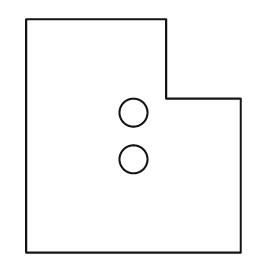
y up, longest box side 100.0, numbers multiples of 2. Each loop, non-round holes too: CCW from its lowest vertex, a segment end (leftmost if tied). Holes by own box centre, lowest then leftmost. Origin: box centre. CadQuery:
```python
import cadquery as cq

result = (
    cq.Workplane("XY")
    .moveTo(-46.0, -50.0)
    .lineTo(46.0, -50.0)
    .lineTo(46.0, 16.0)
    .lineTo(14.0, 16.0)
    .lineTo(14.0, 50.0)
    .lineTo(-46.0, 50.0)
    .close()
    .moveTo(0.0, -10.0)
    .circle(6.0)
    .moveTo(0.0, 10.0)
    .circle(6.0)
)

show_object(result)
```